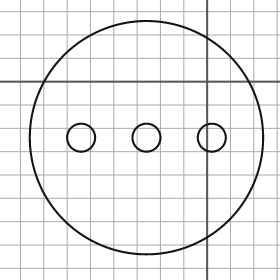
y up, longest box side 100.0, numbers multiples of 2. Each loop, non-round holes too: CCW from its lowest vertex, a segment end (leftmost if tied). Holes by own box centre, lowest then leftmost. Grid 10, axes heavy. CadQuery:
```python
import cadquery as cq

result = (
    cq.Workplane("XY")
    .moveTo(-26.0, -24.0)
    .circle(50.0)
    .moveTo(-54.0, -24.0)
    .circle(6.0)
    .moveTo(-26.0, -24.0)
    .circle(6.0)
    .moveTo(2.0, -24.0)
    .circle(6.0)
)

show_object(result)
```